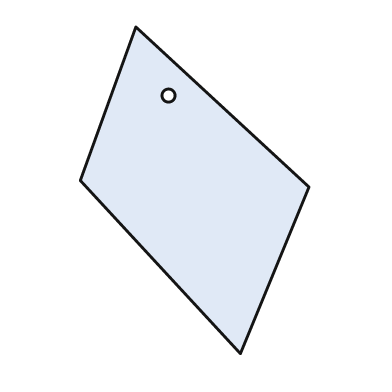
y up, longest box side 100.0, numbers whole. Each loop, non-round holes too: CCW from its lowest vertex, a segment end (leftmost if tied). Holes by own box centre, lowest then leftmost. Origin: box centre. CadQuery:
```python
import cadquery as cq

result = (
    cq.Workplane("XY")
    .moveTo(14.0, -50.0)
    .lineTo(35.0, 1.0)
    .lineTo(-18.0, 50.0)
    .lineTo(-35.0, 3.0)
    .close()
    .moveTo(-8.0, 29.0)
    .circle(2.0)
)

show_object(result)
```